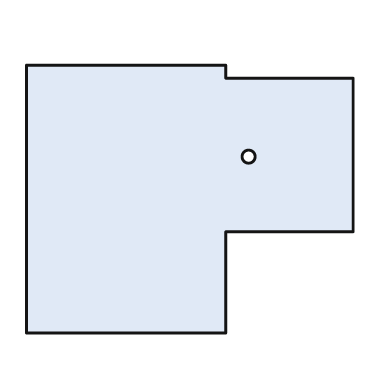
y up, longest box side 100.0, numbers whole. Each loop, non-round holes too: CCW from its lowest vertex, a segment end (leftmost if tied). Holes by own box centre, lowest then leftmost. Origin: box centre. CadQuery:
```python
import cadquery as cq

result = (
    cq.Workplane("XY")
    .moveTo(-50.0, -41.0)
    .lineTo(11.0, -41.0)
    .lineTo(11.0, -10.0)
    .lineTo(50.0, -10.0)
    .lineTo(50.0, 37.0)
    .lineTo(11.0, 37.0)
    .lineTo(11.0, 41.0)
    .lineTo(-50.0, 41.0)
    .close()
    .moveTo(18.0, 13.0)
    .circle(2.0)
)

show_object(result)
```